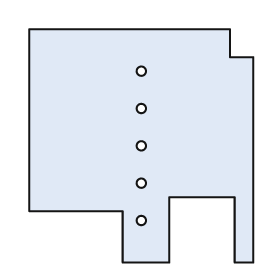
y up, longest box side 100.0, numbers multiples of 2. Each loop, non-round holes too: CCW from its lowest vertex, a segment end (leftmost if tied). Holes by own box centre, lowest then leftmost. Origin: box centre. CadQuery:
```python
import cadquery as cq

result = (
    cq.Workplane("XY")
    .moveTo(-8.0, -50.0)
    .lineTo(12.0, -50.0)
    .lineTo(12.0, -22.0)
    .lineTo(40.0, -22.0)
    .lineTo(40.0, -50.0)
    .lineTo(48.0, -50.0)
    .lineTo(48.0, 38.0)
    .lineTo(38.0, 38.0)
    .lineTo(38.0, 50.0)
    .lineTo(-48.0, 50.0)
    .lineTo(-48.0, -28.0)
    .lineTo(-8.0, -28.0)
    .close()
    .moveTo(0.0, -32.0)
    .circle(2.0)
    .moveTo(0.0, -16.0)
    .circle(2.0)
    .moveTo(0.0, 0.0)
    .circle(2.0)
    .moveTo(0.0, 16.0)
    .circle(2.0)
    .moveTo(0.0, 32.0)
    .circle(2.0)
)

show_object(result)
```